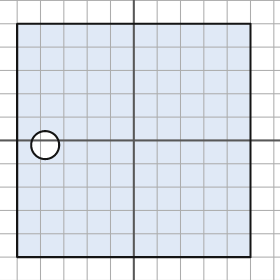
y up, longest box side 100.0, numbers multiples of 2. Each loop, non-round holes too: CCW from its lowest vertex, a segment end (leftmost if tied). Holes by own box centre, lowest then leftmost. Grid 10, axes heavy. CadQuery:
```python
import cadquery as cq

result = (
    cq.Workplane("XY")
    .moveTo(-50.0, -50.0)
    .lineTo(50.0, -50.0)
    .lineTo(50.0, 50.0)
    .lineTo(-50.0, 50.0)
    .close()
    .moveTo(-38.0, -2.0)
    .circle(6.0)
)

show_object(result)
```